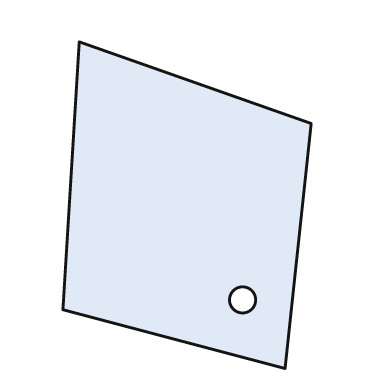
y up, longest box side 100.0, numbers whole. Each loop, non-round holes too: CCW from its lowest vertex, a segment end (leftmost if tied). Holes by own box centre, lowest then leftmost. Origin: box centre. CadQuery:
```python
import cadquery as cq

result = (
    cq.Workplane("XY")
    .moveTo(30.0, -50.0)
    .lineTo(38.0, 25.0)
    .lineTo(-33.0, 50.0)
    .lineTo(-38.0, -32.0)
    .close()
    .moveTo(17.0, -29.0)
    .circle(4.0)
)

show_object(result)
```